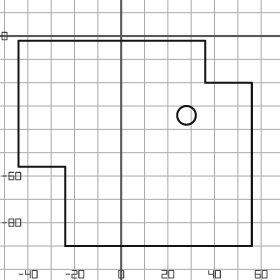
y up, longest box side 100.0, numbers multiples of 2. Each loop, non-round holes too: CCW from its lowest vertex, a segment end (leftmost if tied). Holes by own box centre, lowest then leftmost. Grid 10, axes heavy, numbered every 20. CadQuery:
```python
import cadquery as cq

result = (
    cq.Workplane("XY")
    .moveTo(-24.0, -90.0)
    .lineTo(56.0, -90.0)
    .lineTo(56.0, -20.0)
    .lineTo(36.0, -20.0)
    .lineTo(36.0, -2.0)
    .lineTo(-44.0, -2.0)
    .lineTo(-44.0, -56.0)
    .lineTo(-24.0, -56.0)
    .close()
    .moveTo(28.0, -34.0)
    .circle(4.0)
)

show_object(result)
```